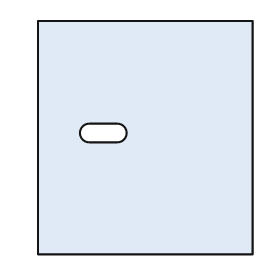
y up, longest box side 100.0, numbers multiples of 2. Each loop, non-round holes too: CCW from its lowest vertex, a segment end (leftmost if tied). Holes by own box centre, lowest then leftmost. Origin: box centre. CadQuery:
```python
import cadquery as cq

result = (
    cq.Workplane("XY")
    .moveTo(-46.0, -50.0)
    .lineTo(46.0, -50.0)
    .lineTo(46.0, 50.0)
    .lineTo(-46.0, 50.0)
    .close()
    .moveTo(-24.0, -2.0)
    .lineTo(-12.0, -2.0)
    .threePointArc((-8.0, 2.0), (-12.0, 6.0))
    .lineTo(-24.0, 6.0)
    .threePointArc((-28.0, 2.0), (-24.0, -2.0))
    .close()
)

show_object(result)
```